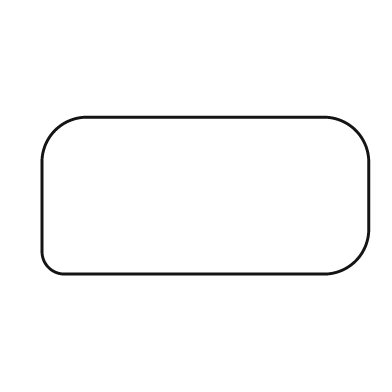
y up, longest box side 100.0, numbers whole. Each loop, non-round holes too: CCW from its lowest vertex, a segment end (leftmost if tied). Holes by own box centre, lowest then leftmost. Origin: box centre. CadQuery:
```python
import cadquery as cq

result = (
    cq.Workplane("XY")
    .moveTo(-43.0, -24.0)
    .lineTo(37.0, -24.0)
    .threePointArc((46.0, -20.0), (50.0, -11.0))
    .lineTo(50.0, 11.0)
    .threePointArc((46.0, 20.0), (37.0, 24.0))
    .lineTo(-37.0, 24.0)
    .threePointArc((-46.0, 20.0), (-50.0, 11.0))
    .lineTo(-50.0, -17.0)
    .threePointArc((-48.0, -22.0), (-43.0, -24.0))
    .close()
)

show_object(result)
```